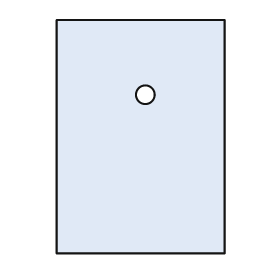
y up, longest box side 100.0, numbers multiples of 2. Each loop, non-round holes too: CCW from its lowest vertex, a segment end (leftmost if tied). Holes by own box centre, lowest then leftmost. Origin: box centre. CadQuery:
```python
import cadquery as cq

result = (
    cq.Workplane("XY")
    .moveTo(-36.0, -50.0)
    .lineTo(36.0, -50.0)
    .lineTo(36.0, 50.0)
    .lineTo(-36.0, 50.0)
    .close()
    .moveTo(2.0, 18.0)
    .circle(4.0)
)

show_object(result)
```